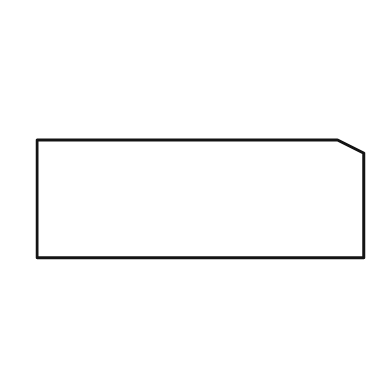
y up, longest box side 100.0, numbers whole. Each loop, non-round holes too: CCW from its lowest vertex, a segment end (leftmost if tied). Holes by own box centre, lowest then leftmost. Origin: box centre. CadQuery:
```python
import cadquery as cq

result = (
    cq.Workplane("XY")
    .moveTo(-50.0, -18.0)
    .lineTo(50.0, -18.0)
    .lineTo(50.0, 14.0)
    .lineTo(42.0, 18.0)
    .lineTo(-50.0, 18.0)
    .close()
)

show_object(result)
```